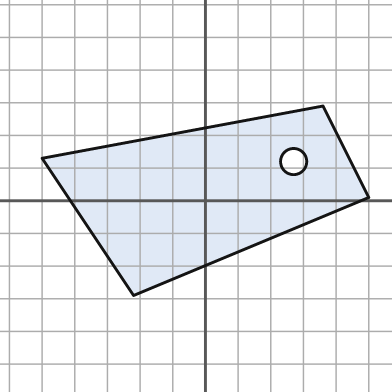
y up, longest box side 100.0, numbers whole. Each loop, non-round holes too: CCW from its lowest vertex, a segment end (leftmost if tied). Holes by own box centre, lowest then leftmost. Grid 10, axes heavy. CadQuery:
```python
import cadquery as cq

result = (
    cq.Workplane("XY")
    .moveTo(-22.0, -29.0)
    .lineTo(50.0, 1.0)
    .lineTo(36.0, 29.0)
    .lineTo(-50.0, 13.0)
    .close()
    .moveTo(27.0, 12.0)
    .circle(4.0)
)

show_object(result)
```